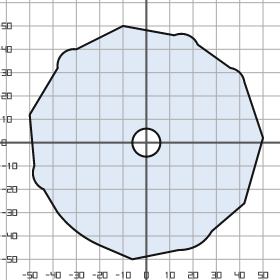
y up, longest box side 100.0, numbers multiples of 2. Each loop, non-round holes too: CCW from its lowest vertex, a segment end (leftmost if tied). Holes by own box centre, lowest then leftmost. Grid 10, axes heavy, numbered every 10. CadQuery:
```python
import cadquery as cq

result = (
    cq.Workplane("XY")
    .moveTo(-6.0, -50.0)
    .lineTo(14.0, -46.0)
    .threePointArc((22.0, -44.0), (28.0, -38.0))
    .lineTo(42.0, -26.0)
    .lineTo(50.0, 2.0)
    .lineTo(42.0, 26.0)
    .threePointArc((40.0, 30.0), (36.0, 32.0))
    .lineTo(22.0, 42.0)
    .threePointArc((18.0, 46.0), (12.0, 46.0))
    .lineTo(-10.0, 50.0)
    .lineTo(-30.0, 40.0)
    .threePointArc((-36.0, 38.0), (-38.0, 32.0))
    .lineTo(-50.0, 12.0)
    .lineTo(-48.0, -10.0)
    .threePointArc((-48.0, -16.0), (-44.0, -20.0))
    .lineTo(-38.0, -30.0)
    .threePointArc((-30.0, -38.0), (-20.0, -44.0))
    .close()
    .moveTo(0.0, 0.0)
    .circle(6.0)
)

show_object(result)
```